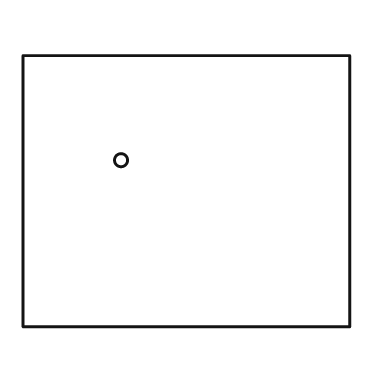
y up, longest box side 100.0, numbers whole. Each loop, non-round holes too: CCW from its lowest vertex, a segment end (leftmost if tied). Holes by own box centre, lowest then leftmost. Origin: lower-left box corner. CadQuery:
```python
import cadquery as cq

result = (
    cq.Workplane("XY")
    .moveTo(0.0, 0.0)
    .lineTo(100.0, 0.0)
    .lineTo(100.0, 83.0)
    .lineTo(0.0, 83.0)
    .close()
    .moveTo(30.0, 51.0)
    .circle(2.0)
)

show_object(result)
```